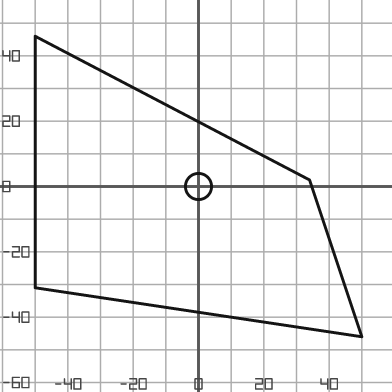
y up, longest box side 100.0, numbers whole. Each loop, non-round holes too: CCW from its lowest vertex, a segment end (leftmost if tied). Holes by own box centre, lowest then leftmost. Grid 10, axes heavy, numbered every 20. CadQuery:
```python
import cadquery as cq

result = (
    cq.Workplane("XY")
    .moveTo(50.0, -46.0)
    .lineTo(34.0, 2.0)
    .lineTo(-50.0, 46.0)
    .lineTo(-50.0, -31.0)
    .close()
    .moveTo(0.0, 0.0)
    .circle(4.0)
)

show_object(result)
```